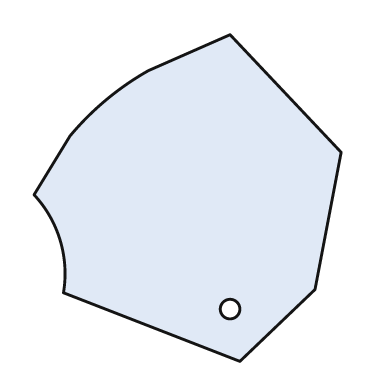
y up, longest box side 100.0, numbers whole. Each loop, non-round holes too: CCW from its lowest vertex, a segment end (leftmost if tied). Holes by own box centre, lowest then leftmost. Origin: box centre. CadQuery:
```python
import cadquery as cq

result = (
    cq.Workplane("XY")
    .moveTo(16.0, -50.0)
    .lineTo(39.0, -28.0)
    .lineTo(47.0, 14.0)
    .lineTo(13.0, 50.0)
    .lineTo(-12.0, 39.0)
    .threePointArc((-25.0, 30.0), (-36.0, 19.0))
    .lineTo(-47.0, 1.0)
    .threePointArc((-39.0, -13.0), (-38.0, -29.0))
    .close()
    .moveTo(13.0, -34.0)
    .circle(3.0)
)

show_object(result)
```